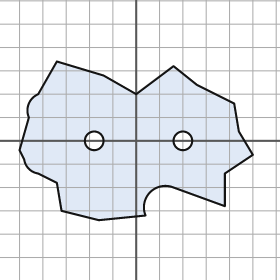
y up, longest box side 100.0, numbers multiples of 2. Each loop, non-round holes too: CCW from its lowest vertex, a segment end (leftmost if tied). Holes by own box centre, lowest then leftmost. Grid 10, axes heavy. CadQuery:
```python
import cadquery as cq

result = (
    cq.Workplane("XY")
    .moveTo(-16.0, -34.0)
    .lineTo(4.0, -32.0)
    .threePointArc((6.0, -22.0), (16.0, -20.0))
    .lineTo(38.0, -28.0)
    .lineTo(38.0, -14.0)
    .lineTo(50.0, -6.0)
    .lineTo(44.0, 4.0)
    .lineTo(42.0, 16.0)
    .lineTo(26.0, 24.0)
    .lineTo(16.0, 32.0)
    .lineTo(0.0, 20.0)
    .lineTo(-14.0, 28.0)
    .lineTo(-34.0, 34.0)
    .lineTo(-42.0, 20.0)
    .threePointArc((-46.0, 16.0), (-46.0, 10.0))
    .lineTo(-50.0, -4.0)
    .lineTo(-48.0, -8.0)
    .threePointArc((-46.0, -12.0), (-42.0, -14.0))
    .lineTo(-34.0, -18.0)
    .lineTo(-32.0, -30.0)
    .close()
    .moveTo(-18.0, 0.0)
    .circle(4.0)
    .moveTo(20.0, 0.0)
    .circle(4.0)
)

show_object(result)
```